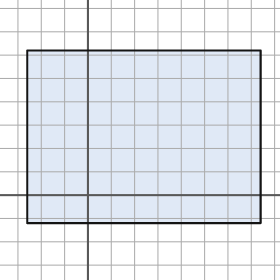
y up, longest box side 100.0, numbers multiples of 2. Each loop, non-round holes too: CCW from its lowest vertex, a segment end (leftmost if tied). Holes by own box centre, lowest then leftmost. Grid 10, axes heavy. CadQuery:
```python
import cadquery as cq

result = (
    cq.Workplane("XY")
    .moveTo(-26.0, -12.0)
    .lineTo(74.0, -12.0)
    .lineTo(74.0, 62.0)
    .lineTo(-26.0, 62.0)
    .close()
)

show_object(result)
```